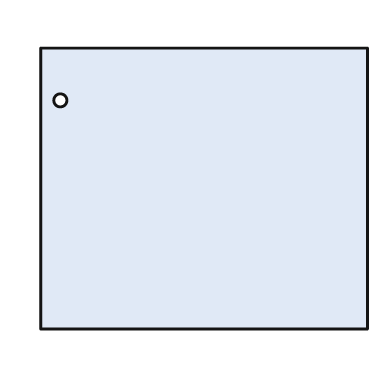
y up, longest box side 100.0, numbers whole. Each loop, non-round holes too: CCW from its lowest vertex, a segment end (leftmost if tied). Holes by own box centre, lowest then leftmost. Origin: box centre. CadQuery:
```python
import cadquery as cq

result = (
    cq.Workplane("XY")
    .moveTo(-50.0, -43.0)
    .lineTo(50.0, -43.0)
    .lineTo(50.0, 43.0)
    .lineTo(-50.0, 43.0)
    .close()
    .moveTo(-44.0, 27.0)
    .circle(2.0)
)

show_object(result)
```